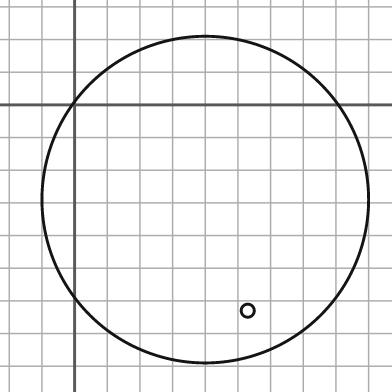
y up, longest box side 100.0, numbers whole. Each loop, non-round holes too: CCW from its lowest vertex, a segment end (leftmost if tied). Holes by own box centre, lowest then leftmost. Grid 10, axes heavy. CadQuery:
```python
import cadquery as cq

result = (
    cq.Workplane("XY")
    .moveTo(40.0, -29.0)
    .circle(50.0)
    .moveTo(53.0, -63.0)
    .circle(2.0)
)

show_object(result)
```